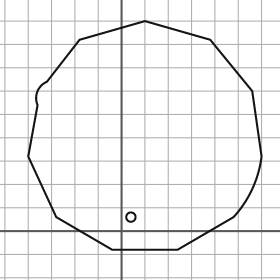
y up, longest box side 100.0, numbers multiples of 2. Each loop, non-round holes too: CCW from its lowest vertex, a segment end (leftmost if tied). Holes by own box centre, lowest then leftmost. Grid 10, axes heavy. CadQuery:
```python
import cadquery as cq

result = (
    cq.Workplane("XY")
    .moveTo(-4.0, -8.0)
    .lineTo(24.0, -8.0)
    .lineTo(48.0, 6.0)
    .threePointArc((56.0, 18.0), (60.0, 32.0))
    .lineTo(56.0, 60.0)
    .lineTo(38.0, 82.0)
    .lineTo(10.0, 90.0)
    .lineTo(-18.0, 82.0)
    .lineTo(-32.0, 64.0)
    .threePointArc((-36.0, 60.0), (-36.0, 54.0))
    .lineTo(-40.0, 32.0)
    .lineTo(-28.0, 6.0)
    .close()
    .moveTo(4.0, 6.0)
    .circle(2.0)
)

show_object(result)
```